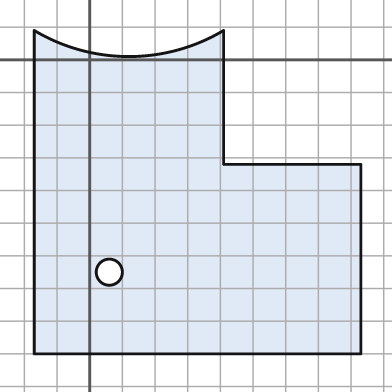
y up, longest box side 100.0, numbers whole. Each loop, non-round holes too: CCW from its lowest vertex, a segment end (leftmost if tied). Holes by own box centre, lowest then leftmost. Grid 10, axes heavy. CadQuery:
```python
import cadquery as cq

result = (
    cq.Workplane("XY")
    .moveTo(-17.0, -90.0)
    .lineTo(83.0, -90.0)
    .lineTo(83.0, -32.0)
    .lineTo(41.0, -32.0)
    .lineTo(41.0, 9.0)
    .threePointArc((12.0, 1.0), (-17.0, 9.0))
    .close()
    .moveTo(6.0, -65.0)
    .circle(4.0)
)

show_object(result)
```